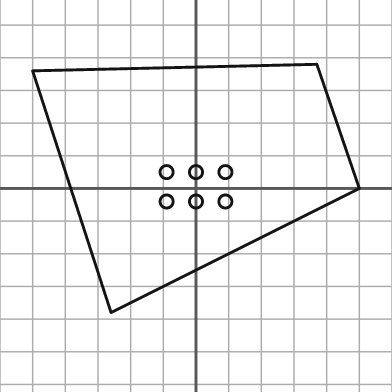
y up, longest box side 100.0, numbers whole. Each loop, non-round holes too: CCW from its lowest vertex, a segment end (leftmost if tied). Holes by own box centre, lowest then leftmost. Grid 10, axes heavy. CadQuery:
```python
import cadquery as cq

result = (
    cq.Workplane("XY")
    .moveTo(-26.0, -38.0)
    .lineTo(50.0, 0.0)
    .lineTo(37.0, 38.0)
    .lineTo(-50.0, 36.0)
    .close()
    .moveTo(-9.0, -4.0)
    .circle(2.0)
    .moveTo(0.0, -4.0)
    .circle(2.0)
    .moveTo(9.0, -4.0)
    .circle(2.0)
    .moveTo(-9.0, 5.0)
    .circle(2.0)
    .moveTo(0.0, 5.0)
    .circle(2.0)
    .moveTo(9.0, 5.0)
    .circle(2.0)
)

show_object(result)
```